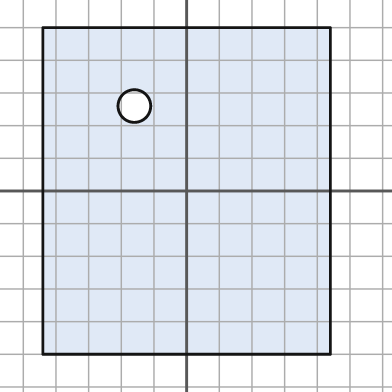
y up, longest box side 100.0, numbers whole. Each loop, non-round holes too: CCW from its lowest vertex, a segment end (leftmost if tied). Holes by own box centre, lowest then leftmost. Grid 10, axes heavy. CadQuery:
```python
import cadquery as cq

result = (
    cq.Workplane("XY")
    .moveTo(-44.0, -50.0)
    .lineTo(44.0, -50.0)
    .lineTo(44.0, 50.0)
    .lineTo(-44.0, 50.0)
    .close()
    .moveTo(-16.0, 26.0)
    .circle(5.0)
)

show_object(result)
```